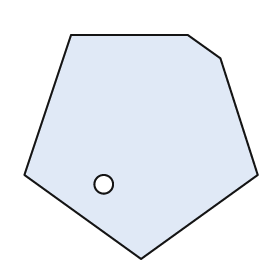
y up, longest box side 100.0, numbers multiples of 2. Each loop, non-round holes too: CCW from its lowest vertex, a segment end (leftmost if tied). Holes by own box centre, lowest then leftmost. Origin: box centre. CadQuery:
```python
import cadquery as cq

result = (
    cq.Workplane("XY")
    .moveTo(0.0, -48.0)
    .lineTo(50.0, -12.0)
    .lineTo(34.0, 38.0)
    .lineTo(20.0, 48.0)
    .lineTo(-30.0, 48.0)
    .lineTo(-50.0, -12.0)
    .close()
    .moveTo(-16.0, -16.0)
    .circle(4.0)
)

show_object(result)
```